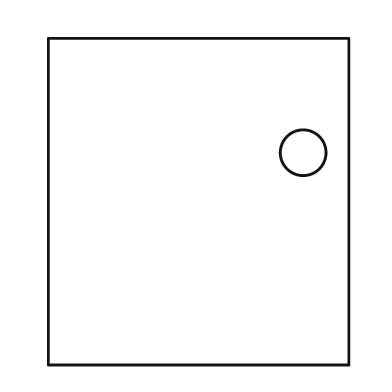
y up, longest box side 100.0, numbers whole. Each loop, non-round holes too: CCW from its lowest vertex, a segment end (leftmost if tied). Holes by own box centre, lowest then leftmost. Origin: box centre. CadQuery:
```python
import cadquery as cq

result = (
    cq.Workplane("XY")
    .moveTo(-46.0, -50.0)
    .lineTo(46.0, -50.0)
    .lineTo(46.0, 50.0)
    .lineTo(-46.0, 50.0)
    .close()
    .moveTo(32.0, 15.0)
    .circle(7.0)
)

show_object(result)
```